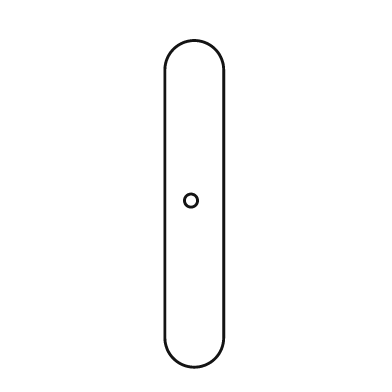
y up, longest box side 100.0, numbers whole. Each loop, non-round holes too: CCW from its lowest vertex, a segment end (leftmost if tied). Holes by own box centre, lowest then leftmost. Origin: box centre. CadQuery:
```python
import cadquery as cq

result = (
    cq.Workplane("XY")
    .moveTo(-9.0, -41.0)
    .threePointArc((0.0, -50.0), (9.0, -41.0))
    .lineTo(9.0, 41.0)
    .threePointArc((0.0, 50.0), (-9.0, 41.0))
    .close()
    .moveTo(-1.0, 1.0)
    .circle(2.0)
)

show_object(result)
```